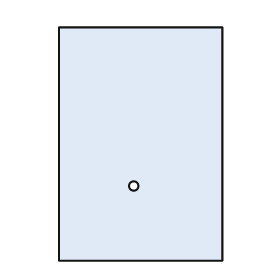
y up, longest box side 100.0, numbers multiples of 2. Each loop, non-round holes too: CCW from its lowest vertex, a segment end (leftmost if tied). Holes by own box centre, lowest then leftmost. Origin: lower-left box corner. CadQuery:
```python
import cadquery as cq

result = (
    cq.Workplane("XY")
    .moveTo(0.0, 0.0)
    .lineTo(70.0, 0.0)
    .lineTo(70.0, 100.0)
    .lineTo(0.0, 100.0)
    .close()
    .moveTo(32.0, 32.0)
    .circle(2.0)
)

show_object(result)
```